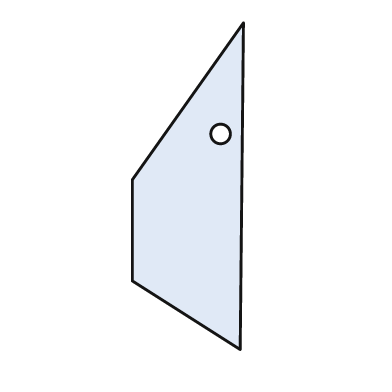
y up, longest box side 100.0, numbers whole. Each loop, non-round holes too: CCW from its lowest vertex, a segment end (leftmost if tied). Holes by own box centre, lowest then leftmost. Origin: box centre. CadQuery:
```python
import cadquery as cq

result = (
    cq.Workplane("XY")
    .moveTo(16.0, -50.0)
    .lineTo(17.0, 50.0)
    .lineTo(-17.0, 2.0)
    .lineTo(-17.0, -29.0)
    .close()
    .moveTo(10.0, 16.0)
    .circle(3.0)
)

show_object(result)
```